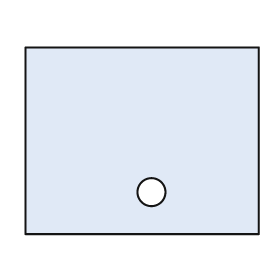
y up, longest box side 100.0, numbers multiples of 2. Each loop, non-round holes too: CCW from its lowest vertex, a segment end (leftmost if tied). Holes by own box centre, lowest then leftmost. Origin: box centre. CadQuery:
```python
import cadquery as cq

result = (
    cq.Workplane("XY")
    .moveTo(-50.0, -40.0)
    .lineTo(50.0, -40.0)
    .lineTo(50.0, 40.0)
    .lineTo(-50.0, 40.0)
    .close()
    .moveTo(4.0, -22.0)
    .circle(6.0)
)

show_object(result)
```